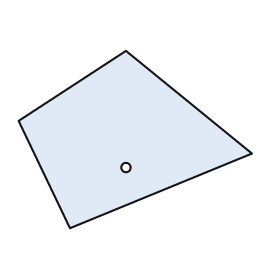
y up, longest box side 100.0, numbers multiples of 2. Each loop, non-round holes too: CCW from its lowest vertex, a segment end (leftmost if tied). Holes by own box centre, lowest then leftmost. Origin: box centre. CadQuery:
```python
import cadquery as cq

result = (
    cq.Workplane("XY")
    .moveTo(-28.0, -38.0)
    .lineTo(50.0, -6.0)
    .lineTo(-4.0, 38.0)
    .lineTo(-50.0, 8.0)
    .close()
    .moveTo(-4.0, -12.0)
    .circle(2.0)
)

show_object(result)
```